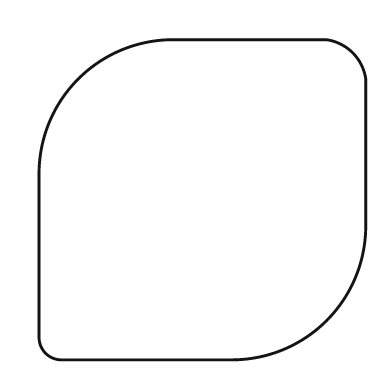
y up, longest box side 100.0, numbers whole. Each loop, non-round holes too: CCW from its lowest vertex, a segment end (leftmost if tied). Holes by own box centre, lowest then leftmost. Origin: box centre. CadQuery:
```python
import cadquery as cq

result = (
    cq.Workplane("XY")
    .moveTo(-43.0, -49.0)
    .lineTo(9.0, -49.0)
    .threePointArc((38.0, -37.0), (50.0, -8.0))
    .lineTo(50.0, 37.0)
    .threePointArc((46.0, 45.0), (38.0, 49.0))
    .lineTo(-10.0, 49.0)
    .threePointArc((-38.0, 37.0), (-50.0, 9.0))
    .lineTo(-50.0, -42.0)
    .threePointArc((-48.0, -47.0), (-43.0, -49.0))
    .close()
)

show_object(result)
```